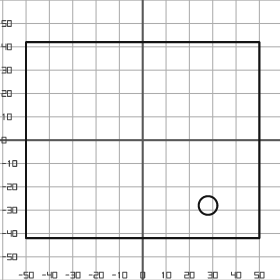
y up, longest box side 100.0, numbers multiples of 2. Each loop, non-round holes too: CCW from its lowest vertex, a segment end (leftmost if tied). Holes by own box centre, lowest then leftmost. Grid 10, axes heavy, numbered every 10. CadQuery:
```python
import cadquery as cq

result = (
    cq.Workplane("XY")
    .moveTo(-50.0, -42.0)
    .lineTo(50.0, -42.0)
    .lineTo(50.0, 42.0)
    .lineTo(-50.0, 42.0)
    .close()
    .moveTo(28.0, -28.0)
    .circle(4.0)
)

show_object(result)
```